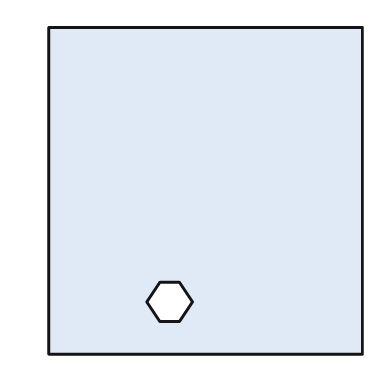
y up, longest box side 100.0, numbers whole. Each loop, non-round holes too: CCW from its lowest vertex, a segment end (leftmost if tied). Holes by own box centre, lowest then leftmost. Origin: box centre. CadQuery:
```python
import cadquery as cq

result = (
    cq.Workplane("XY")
    .moveTo(-48.0, -50.0)
    .lineTo(48.0, -50.0)
    .lineTo(48.0, 50.0)
    .lineTo(-48.0, 50.0)
    .close()
    .moveTo(-14.0, -40.0)
    .lineTo(-8.0, -40.0)
    .lineTo(-4.0, -34.0)
    .lineTo(-8.0, -28.0)
    .lineTo(-14.0, -28.0)
    .lineTo(-18.0, -34.0)
    .close()
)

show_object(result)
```